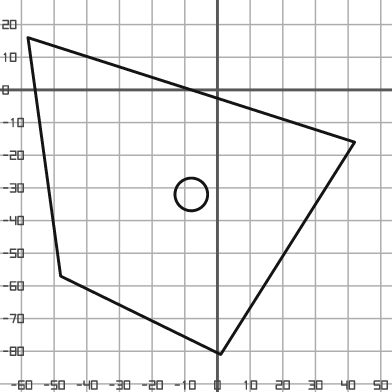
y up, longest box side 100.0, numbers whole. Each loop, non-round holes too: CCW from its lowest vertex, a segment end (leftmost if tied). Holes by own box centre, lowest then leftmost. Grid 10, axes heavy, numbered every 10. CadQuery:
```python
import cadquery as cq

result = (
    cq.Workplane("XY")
    .moveTo(1.0, -81.0)
    .lineTo(42.0, -16.0)
    .lineTo(-58.0, 16.0)
    .lineTo(-48.0, -57.0)
    .close()
    .moveTo(-8.0, -32.0)
    .circle(5.0)
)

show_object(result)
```